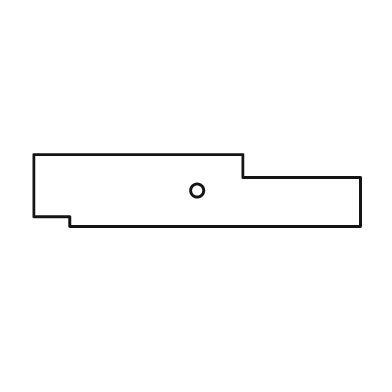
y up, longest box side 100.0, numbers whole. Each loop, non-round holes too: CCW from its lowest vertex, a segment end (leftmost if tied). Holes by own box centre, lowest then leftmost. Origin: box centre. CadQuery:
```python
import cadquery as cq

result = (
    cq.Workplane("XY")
    .moveTo(-39.0, -11.0)
    .lineTo(50.0, -11.0)
    .lineTo(50.0, 4.0)
    .lineTo(14.0, 4.0)
    .lineTo(14.0, 11.0)
    .lineTo(-50.0, 11.0)
    .lineTo(-50.0, -8.0)
    .lineTo(-39.0, -8.0)
    .close()
    .moveTo(0.0, 0.0)
    .circle(2.0)
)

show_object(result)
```